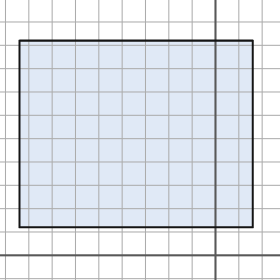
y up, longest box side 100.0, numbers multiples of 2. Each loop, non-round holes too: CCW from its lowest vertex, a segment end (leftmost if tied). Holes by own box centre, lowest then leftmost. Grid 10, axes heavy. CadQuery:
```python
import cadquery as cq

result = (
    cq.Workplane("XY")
    .moveTo(-84.0, 12.0)
    .lineTo(16.0, 12.0)
    .lineTo(16.0, 92.0)
    .lineTo(-84.0, 92.0)
    .close()
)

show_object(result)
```